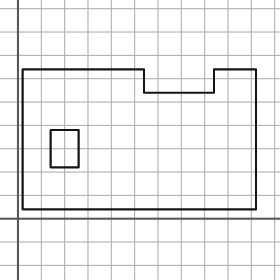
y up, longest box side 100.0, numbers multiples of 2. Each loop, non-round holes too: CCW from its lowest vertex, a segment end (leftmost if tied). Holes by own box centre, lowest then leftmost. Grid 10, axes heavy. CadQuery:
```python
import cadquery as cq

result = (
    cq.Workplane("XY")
    .moveTo(2.0, 4.0)
    .lineTo(102.0, 4.0)
    .lineTo(102.0, 64.0)
    .lineTo(84.0, 64.0)
    .lineTo(84.0, 54.0)
    .lineTo(54.0, 54.0)
    .lineTo(54.0, 64.0)
    .lineTo(2.0, 64.0)
    .close()
    .moveTo(14.0, 22.0)
    .lineTo(26.0, 22.0)
    .lineTo(26.0, 38.0)
    .lineTo(14.0, 38.0)
    .close()
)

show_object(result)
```